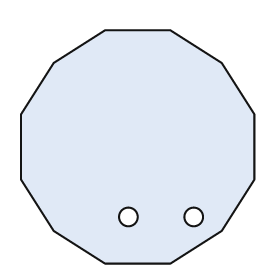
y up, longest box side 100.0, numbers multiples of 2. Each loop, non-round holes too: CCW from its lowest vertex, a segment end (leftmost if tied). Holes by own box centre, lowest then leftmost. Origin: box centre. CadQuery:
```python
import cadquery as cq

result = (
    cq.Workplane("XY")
    .moveTo(-14.0, -50.0)
    .lineTo(14.0, -50.0)
    .lineTo(36.0, -36.0)
    .lineTo(50.0, -14.0)
    .lineTo(50.0, 14.0)
    .lineTo(36.0, 36.0)
    .lineTo(14.0, 50.0)
    .lineTo(-14.0, 50.0)
    .lineTo(-36.0, 36.0)
    .lineTo(-50.0, 14.0)
    .lineTo(-50.0, -14.0)
    .lineTo(-36.0, -36.0)
    .close()
    .moveTo(-4.0, -30.0)
    .circle(4.0)
    .moveTo(24.0, -30.0)
    .circle(4.0)
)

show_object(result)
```